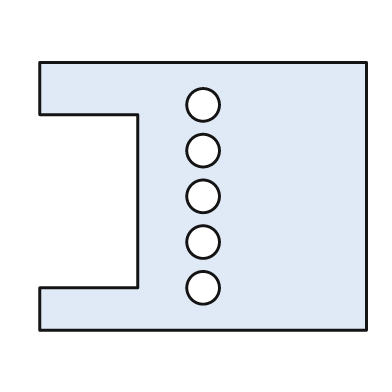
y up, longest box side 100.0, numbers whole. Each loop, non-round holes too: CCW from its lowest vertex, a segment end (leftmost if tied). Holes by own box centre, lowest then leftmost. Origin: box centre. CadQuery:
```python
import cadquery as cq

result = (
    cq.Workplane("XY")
    .moveTo(-50.0, -41.0)
    .lineTo(50.0, -41.0)
    .lineTo(50.0, 41.0)
    .lineTo(-50.0, 41.0)
    .lineTo(-50.0, 25.0)
    .lineTo(-20.0, 25.0)
    .lineTo(-20.0, -28.0)
    .lineTo(-50.0, -28.0)
    .close()
    .moveTo(0.0, -28.0)
    .circle(5.0)
    .moveTo(0.0, -14.0)
    .circle(5.0)
    .moveTo(0.0, 0.0)
    .circle(5.0)
    .moveTo(0.0, 14.0)
    .circle(5.0)
    .moveTo(0.0, 28.0)
    .circle(5.0)
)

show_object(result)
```